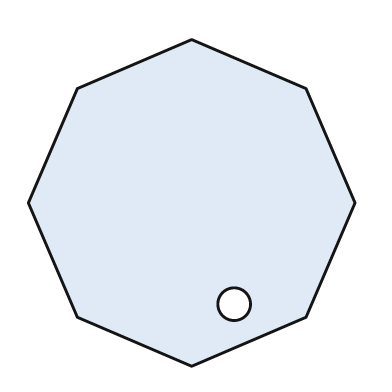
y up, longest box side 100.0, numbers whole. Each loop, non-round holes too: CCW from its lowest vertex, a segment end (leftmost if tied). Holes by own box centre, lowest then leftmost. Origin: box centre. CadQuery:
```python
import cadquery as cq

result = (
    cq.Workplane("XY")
    .moveTo(0.0, -50.0)
    .lineTo(35.0, -35.0)
    .lineTo(50.0, 0.0)
    .lineTo(35.0, 35.0)
    .lineTo(0.0, 50.0)
    .lineTo(-35.0, 35.0)
    .lineTo(-50.0, 0.0)
    .lineTo(-35.0, -35.0)
    .close()
    .moveTo(13.0, -31.0)
    .circle(5.0)
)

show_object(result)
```